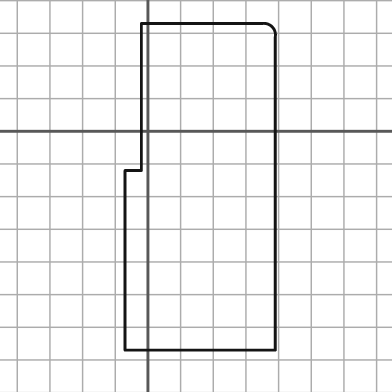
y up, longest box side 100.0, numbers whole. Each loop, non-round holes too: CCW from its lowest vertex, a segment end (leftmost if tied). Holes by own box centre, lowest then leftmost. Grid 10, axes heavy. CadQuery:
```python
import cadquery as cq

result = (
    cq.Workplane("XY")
    .moveTo(-7.0, -67.0)
    .lineTo(39.0, -67.0)
    .lineTo(39.0, 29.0)
    .threePointArc((38.0, 32.0), (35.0, 33.0))
    .lineTo(-2.0, 33.0)
    .lineTo(-2.0, -12.0)
    .lineTo(-7.0, -12.0)
    .close()
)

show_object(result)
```